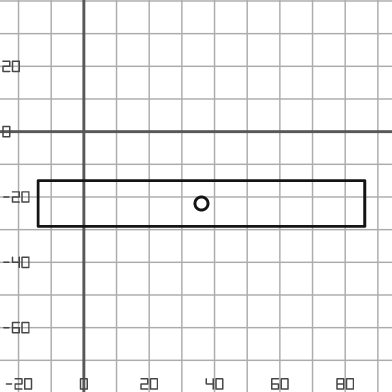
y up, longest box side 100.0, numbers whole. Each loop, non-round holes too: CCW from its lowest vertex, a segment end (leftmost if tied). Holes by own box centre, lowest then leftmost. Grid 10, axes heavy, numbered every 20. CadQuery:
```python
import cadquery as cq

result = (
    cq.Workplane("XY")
    .moveTo(-14.0, -29.0)
    .lineTo(86.0, -29.0)
    .lineTo(86.0, -15.0)
    .lineTo(-14.0, -15.0)
    .close()
    .moveTo(36.0, -22.0)
    .circle(2.0)
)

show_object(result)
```